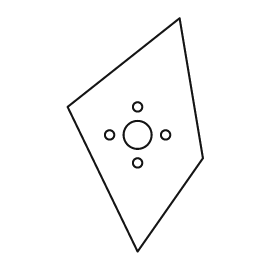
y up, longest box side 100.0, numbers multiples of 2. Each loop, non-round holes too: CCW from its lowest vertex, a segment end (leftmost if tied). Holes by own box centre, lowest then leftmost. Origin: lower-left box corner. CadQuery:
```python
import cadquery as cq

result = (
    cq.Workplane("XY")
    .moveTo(30.0, 0.0)
    .lineTo(58.0, 40.0)
    .lineTo(48.0, 100.0)
    .lineTo(0.0, 62.0)
    .close()
    .moveTo(30.0, 38.0)
    .circle(2.0)
    .moveTo(18.0, 50.0)
    .circle(2.0)
    .moveTo(30.0, 50.0)
    .circle(6.0)
    .moveTo(42.0, 50.0)
    .circle(2.0)
    .moveTo(30.0, 62.0)
    .circle(2.0)
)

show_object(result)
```